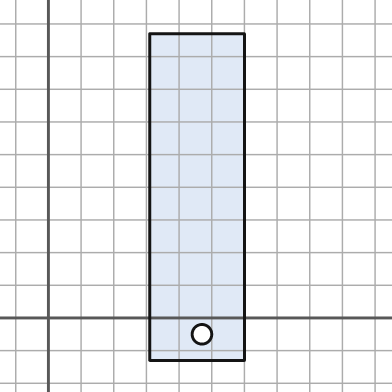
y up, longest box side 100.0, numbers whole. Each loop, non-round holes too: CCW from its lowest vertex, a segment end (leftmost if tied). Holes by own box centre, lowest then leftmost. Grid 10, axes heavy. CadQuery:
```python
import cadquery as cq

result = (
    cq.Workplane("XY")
    .moveTo(31.0, -13.0)
    .lineTo(60.0, -13.0)
    .lineTo(60.0, 87.0)
    .lineTo(31.0, 87.0)
    .close()
    .moveTo(47.0, -5.0)
    .circle(3.0)
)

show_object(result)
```